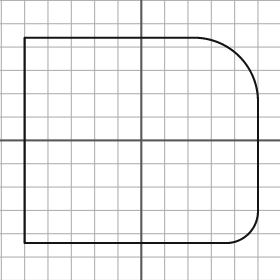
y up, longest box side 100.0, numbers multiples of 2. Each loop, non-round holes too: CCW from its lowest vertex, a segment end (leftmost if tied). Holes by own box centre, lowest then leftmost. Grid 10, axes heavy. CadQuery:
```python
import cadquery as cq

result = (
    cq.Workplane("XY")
    .moveTo(-50.0, -44.0)
    .lineTo(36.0, -44.0)
    .threePointArc((46.0, -40.0), (50.0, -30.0))
    .lineTo(50.0, 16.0)
    .threePointArc((42.0, 36.0), (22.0, 44.0))
    .lineTo(-50.0, 44.0)
    .close()
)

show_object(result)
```